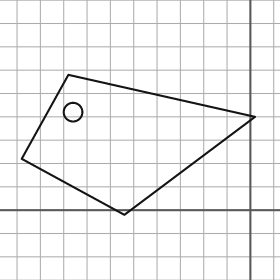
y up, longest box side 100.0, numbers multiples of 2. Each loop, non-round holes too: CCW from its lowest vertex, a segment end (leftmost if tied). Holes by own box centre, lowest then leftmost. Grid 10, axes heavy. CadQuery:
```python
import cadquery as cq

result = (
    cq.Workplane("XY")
    .moveTo(-54.0, -2.0)
    .lineTo(2.0, 40.0)
    .lineTo(-78.0, 58.0)
    .lineTo(-98.0, 22.0)
    .close()
    .moveTo(-76.0, 42.0)
    .circle(4.0)
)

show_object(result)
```